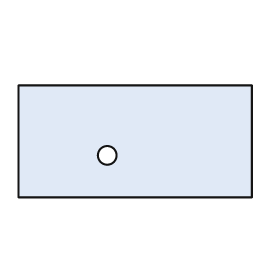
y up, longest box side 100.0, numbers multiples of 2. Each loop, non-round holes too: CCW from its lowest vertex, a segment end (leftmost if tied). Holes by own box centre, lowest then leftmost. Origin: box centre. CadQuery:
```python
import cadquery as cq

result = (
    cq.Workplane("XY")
    .moveTo(-50.0, -24.0)
    .lineTo(50.0, -24.0)
    .lineTo(50.0, 24.0)
    .lineTo(-50.0, 24.0)
    .close()
    .moveTo(-12.0, -6.0)
    .circle(4.0)
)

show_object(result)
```